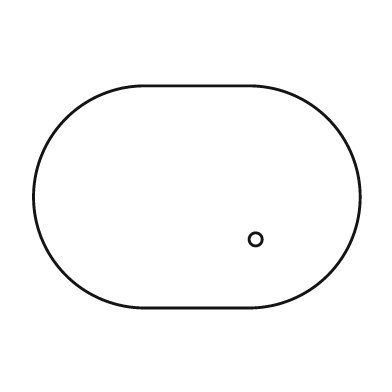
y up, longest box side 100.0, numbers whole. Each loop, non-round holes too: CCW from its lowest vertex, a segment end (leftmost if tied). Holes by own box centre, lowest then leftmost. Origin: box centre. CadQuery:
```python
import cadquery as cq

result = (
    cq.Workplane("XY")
    .moveTo(-16.0, -34.0)
    .lineTo(16.0, -34.0)
    .threePointArc((50.0, 0.0), (16.0, 34.0))
    .lineTo(-16.0, 34.0)
    .threePointArc((-50.0, 0.0), (-16.0, -34.0))
    .close()
    .moveTo(18.0, -13.0)
    .circle(2.0)
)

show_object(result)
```